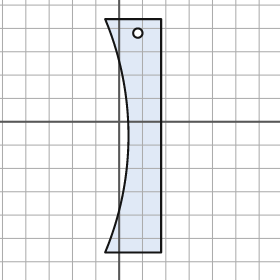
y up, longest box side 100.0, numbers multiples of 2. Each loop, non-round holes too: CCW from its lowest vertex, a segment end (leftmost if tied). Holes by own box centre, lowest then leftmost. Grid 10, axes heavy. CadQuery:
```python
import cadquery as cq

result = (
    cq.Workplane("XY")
    .moveTo(-6.0, -56.0)
    .lineTo(18.0, -56.0)
    .lineTo(18.0, 44.0)
    .lineTo(-6.0, 44.0)
    .threePointArc((4.0, -6.0), (-6.0, -56.0))
    .close()
    .moveTo(8.0, 38.0)
    .circle(2.0)
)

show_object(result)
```